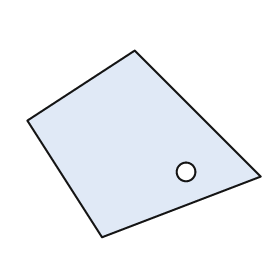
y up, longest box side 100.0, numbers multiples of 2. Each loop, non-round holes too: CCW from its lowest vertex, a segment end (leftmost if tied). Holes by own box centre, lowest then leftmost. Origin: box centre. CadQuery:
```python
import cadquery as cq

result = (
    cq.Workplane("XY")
    .moveTo(-18.0, -40.0)
    .lineTo(50.0, -14.0)
    .lineTo(-4.0, 40.0)
    .lineTo(-50.0, 10.0)
    .close()
    .moveTo(18.0, -12.0)
    .circle(4.0)
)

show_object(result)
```